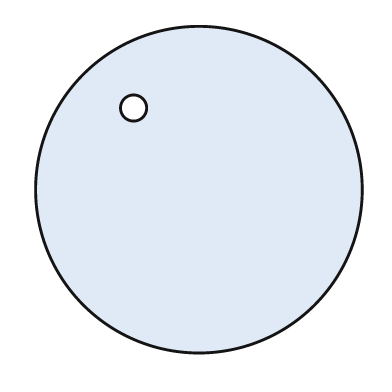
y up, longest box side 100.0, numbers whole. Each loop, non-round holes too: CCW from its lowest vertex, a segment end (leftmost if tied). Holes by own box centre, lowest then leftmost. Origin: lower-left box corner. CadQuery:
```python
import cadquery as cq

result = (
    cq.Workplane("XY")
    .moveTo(50.0, 50.0)
    .circle(50.0)
    .moveTo(30.0, 75.0)
    .circle(4.0)
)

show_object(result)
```